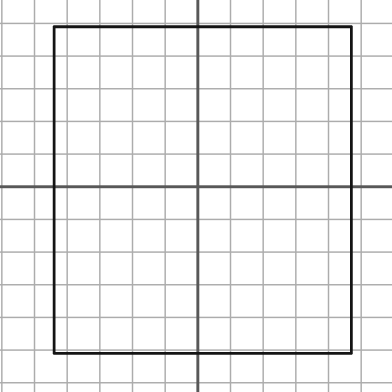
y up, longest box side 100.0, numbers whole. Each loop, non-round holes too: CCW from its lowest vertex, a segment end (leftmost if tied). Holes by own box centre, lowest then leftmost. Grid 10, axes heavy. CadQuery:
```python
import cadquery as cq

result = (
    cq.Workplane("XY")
    .moveTo(-44.0, -51.0)
    .lineTo(47.0, -51.0)
    .lineTo(47.0, 49.0)
    .lineTo(-44.0, 49.0)
    .close()
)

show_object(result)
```